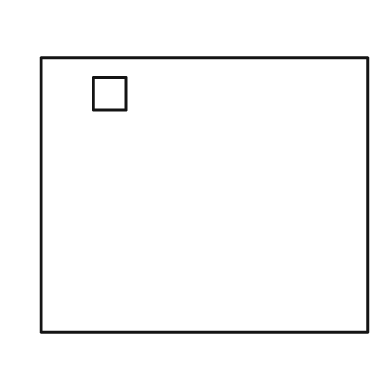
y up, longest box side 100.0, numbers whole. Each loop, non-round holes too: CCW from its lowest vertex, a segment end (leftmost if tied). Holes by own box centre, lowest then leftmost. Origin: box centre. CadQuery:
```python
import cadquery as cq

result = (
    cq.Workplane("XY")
    .moveTo(-50.0, -42.0)
    .lineTo(50.0, -42.0)
    .lineTo(50.0, 42.0)
    .lineTo(-50.0, 42.0)
    .close()
    .moveTo(-34.0, 26.0)
    .lineTo(-24.0, 26.0)
    .lineTo(-24.0, 36.0)
    .lineTo(-34.0, 36.0)
    .close()
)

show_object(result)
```